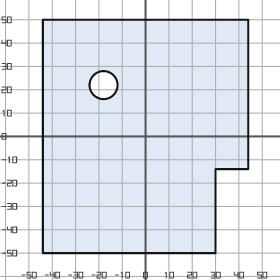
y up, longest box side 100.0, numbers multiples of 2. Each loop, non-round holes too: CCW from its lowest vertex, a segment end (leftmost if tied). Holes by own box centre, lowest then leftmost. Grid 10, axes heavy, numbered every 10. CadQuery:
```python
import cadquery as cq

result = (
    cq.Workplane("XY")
    .moveTo(-44.0, -50.0)
    .lineTo(30.0, -50.0)
    .lineTo(30.0, -14.0)
    .lineTo(44.0, -14.0)
    .lineTo(44.0, 50.0)
    .lineTo(-44.0, 50.0)
    .close()
    .moveTo(-18.0, 22.0)
    .circle(6.0)
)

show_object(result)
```